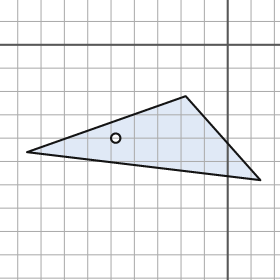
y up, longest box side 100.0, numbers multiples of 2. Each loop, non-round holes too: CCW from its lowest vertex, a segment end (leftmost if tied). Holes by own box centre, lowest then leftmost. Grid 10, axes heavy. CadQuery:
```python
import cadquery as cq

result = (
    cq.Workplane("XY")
    .moveTo(14.0, -58.0)
    .lineTo(-18.0, -22.0)
    .lineTo(-86.0, -46.0)
    .close()
    .moveTo(-48.0, -40.0)
    .circle(2.0)
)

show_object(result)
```